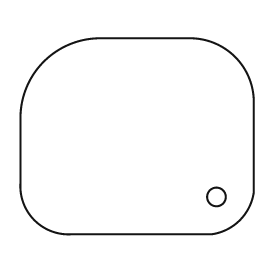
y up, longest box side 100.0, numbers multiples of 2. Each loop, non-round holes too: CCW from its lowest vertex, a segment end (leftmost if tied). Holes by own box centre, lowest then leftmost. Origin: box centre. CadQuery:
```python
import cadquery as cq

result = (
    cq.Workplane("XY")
    .moveTo(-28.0, -42.0)
    .lineTo(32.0, -42.0)
    .threePointArc((44.0, -36.0), (50.0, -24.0))
    .lineTo(50.0, 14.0)
    .threePointArc((42.0, 34.0), (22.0, 42.0))
    .lineTo(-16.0, 42.0)
    .threePointArc((-40.0, 32.0), (-50.0, 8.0))
    .lineTo(-50.0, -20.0)
    .threePointArc((-44.0, -36.0), (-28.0, -42.0))
    .close()
    .moveTo(34.0, -26.0)
    .circle(4.0)
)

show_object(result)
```